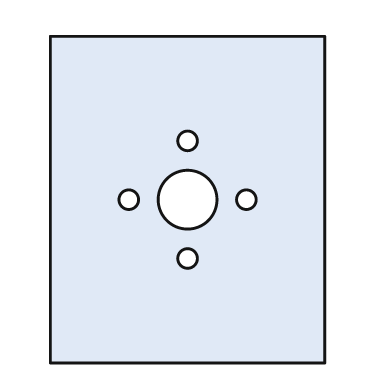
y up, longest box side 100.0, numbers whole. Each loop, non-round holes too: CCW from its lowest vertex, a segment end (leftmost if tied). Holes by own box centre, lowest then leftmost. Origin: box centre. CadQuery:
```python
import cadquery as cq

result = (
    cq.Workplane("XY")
    .moveTo(-42.0, -50.0)
    .lineTo(42.0, -50.0)
    .lineTo(42.0, 50.0)
    .lineTo(-42.0, 50.0)
    .close()
    .moveTo(0.0, -18.0)
    .circle(3.0)
    .moveTo(-18.0, 0.0)
    .circle(3.0)
    .moveTo(0.0, 0.0)
    .circle(9.0)
    .moveTo(18.0, 0.0)
    .circle(3.0)
    .moveTo(0.0, 18.0)
    .circle(3.0)
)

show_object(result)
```